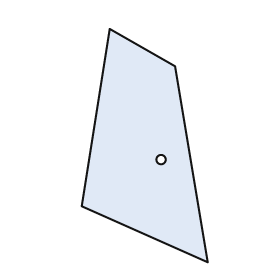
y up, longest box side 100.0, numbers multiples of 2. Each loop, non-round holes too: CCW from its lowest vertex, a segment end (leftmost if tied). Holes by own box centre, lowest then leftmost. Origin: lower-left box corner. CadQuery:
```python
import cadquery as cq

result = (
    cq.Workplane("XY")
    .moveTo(54.0, 0.0)
    .lineTo(40.0, 84.0)
    .lineTo(12.0, 100.0)
    .lineTo(0.0, 24.0)
    .close()
    .moveTo(34.0, 44.0)
    .circle(2.0)
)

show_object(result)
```